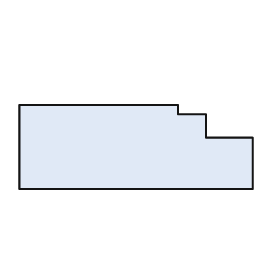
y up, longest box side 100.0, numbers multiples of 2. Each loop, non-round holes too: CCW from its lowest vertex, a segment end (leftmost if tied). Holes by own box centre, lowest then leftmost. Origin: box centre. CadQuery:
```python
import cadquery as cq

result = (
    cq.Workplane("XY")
    .moveTo(-50.0, -18.0)
    .lineTo(50.0, -18.0)
    .lineTo(50.0, 4.0)
    .lineTo(30.0, 4.0)
    .lineTo(30.0, 14.0)
    .lineTo(18.0, 14.0)
    .lineTo(18.0, 18.0)
    .lineTo(-50.0, 18.0)
    .close()
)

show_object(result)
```